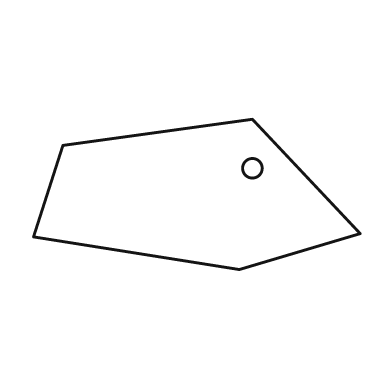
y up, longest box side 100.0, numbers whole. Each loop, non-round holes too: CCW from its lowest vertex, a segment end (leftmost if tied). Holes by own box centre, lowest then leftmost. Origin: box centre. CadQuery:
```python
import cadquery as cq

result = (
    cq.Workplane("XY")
    .moveTo(13.0, -23.0)
    .lineTo(50.0, -12.0)
    .lineTo(17.0, 23.0)
    .lineTo(-41.0, 15.0)
    .lineTo(-50.0, -13.0)
    .close()
    .moveTo(17.0, 8.0)
    .circle(3.0)
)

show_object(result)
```